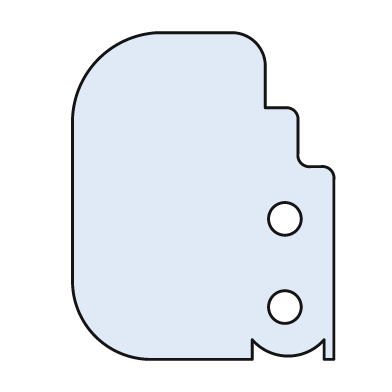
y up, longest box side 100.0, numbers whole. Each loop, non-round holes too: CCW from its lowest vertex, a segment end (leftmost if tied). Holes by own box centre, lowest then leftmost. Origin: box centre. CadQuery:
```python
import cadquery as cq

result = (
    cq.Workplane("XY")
    .moveTo(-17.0, -50.0)
    .lineTo(15.0, -50.0)
    .lineTo(15.0, -44.0)
    .threePointArc((26.0, -49.0), (37.0, -44.0))
    .lineTo(37.0, -50.0)
    .lineTo(40.0, -50.0)
    .lineTo(40.0, 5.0)
    .threePointArc((39.0, 8.0), (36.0, 9.0))
    .lineTo(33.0, 9.0)
    .threePointArc((30.0, 10.0), (29.0, 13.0))
    .lineTo(29.0, 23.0)
    .threePointArc((28.0, 26.0), (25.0, 27.0))
    .lineTo(19.0, 27.0)
    .lineTo(19.0, 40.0)
    .threePointArc((16.0, 47.0), (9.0, 50.0))
    .lineTo(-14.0, 50.0)
    .threePointArc((-32.0, 42.0), (-40.0, 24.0))
    .lineTo(-40.0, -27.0)
    .threePointArc((-33.0, -43.0), (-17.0, -50.0))
    .close()
    .moveTo(25.0, -34.0)
    .circle(5.0)
    .moveTo(25.0, -7.0)
    .circle(5.0)
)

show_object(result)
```